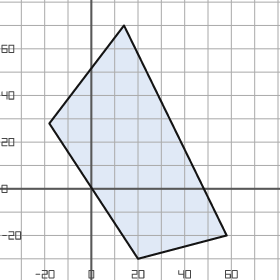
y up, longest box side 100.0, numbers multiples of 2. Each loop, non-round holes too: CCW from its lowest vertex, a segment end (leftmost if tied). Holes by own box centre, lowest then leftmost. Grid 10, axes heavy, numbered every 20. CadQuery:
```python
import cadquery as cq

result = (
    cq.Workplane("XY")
    .moveTo(20.0, -30.0)
    .lineTo(58.0, -20.0)
    .lineTo(14.0, 70.0)
    .lineTo(-18.0, 28.0)
    .close()
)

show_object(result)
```